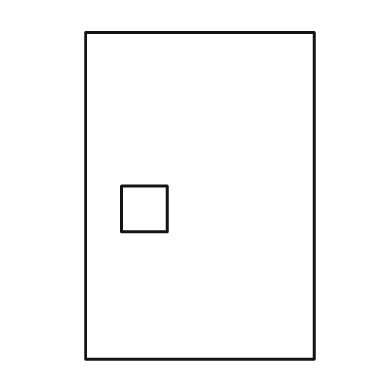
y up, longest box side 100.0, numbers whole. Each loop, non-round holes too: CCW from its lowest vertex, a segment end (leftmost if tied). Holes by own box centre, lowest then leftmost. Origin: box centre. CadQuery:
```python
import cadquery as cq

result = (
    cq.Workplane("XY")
    .moveTo(-35.0, -50.0)
    .lineTo(35.0, -50.0)
    .lineTo(35.0, 50.0)
    .lineTo(-35.0, 50.0)
    .close()
    .moveTo(-24.0, -11.0)
    .lineTo(-10.0, -11.0)
    .lineTo(-10.0, 3.0)
    .lineTo(-24.0, 3.0)
    .close()
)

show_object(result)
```